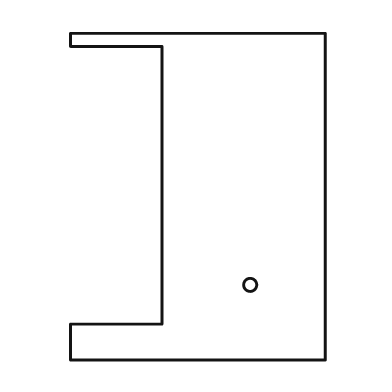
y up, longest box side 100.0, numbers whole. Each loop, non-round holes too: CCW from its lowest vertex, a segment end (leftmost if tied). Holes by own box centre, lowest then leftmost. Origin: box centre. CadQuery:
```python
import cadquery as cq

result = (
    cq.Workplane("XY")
    .moveTo(-39.0, -50.0)
    .lineTo(39.0, -50.0)
    .lineTo(39.0, 50.0)
    .lineTo(-39.0, 50.0)
    .lineTo(-39.0, 46.0)
    .lineTo(-11.0, 46.0)
    .lineTo(-11.0, -39.0)
    .lineTo(-39.0, -39.0)
    .close()
    .moveTo(16.0, -27.0)
    .circle(2.0)
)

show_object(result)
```